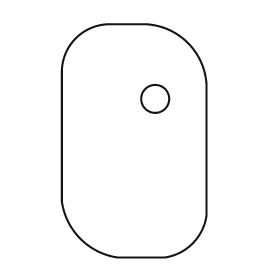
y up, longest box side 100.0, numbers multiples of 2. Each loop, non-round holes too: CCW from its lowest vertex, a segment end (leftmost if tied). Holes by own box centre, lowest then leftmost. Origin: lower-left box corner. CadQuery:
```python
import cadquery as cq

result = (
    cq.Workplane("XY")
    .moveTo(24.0, 0.0)
    .lineTo(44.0, 0.0)
    .threePointArc((56.0, 6.0), (62.0, 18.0))
    .lineTo(62.0, 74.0)
    .threePointArc((54.0, 92.0), (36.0, 100.0))
    .lineTo(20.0, 100.0)
    .threePointArc((6.0, 94.0), (0.0, 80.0))
    .lineTo(0.0, 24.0)
    .threePointArc((8.0, 8.0), (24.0, 0.0))
    .close()
    .moveTo(40.0, 68.0)
    .circle(6.0)
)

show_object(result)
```